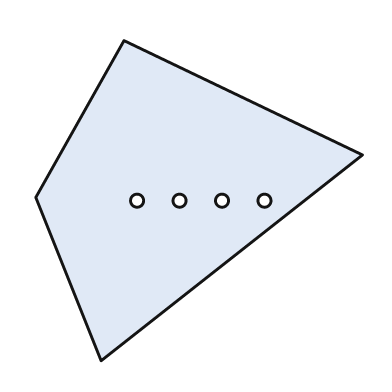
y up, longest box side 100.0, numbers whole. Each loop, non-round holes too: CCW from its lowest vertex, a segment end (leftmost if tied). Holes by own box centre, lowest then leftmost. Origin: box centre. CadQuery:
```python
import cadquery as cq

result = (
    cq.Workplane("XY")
    .moveTo(-30.0, -49.0)
    .lineTo(50.0, 14.0)
    .lineTo(-23.0, 49.0)
    .lineTo(-50.0, 1.0)
    .close()
    .moveTo(-19.0, 0.0)
    .circle(2.0)
    .moveTo(-6.0, 0.0)
    .circle(2.0)
    .moveTo(7.0, 0.0)
    .circle(2.0)
    .moveTo(20.0, 0.0)
    .circle(2.0)
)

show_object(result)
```